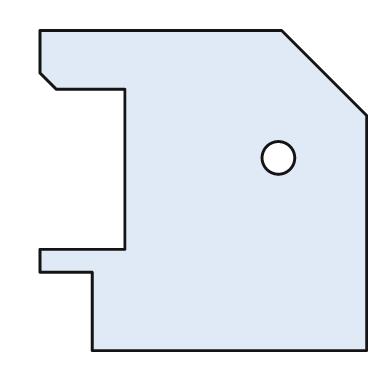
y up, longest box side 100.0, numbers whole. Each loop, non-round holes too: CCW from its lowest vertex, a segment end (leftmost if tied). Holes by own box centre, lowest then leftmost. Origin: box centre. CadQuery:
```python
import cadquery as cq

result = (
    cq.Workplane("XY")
    .moveTo(-34.0, -49.0)
    .lineTo(50.0, -49.0)
    .lineTo(50.0, 23.0)
    .lineTo(24.0, 49.0)
    .lineTo(-50.0, 49.0)
    .lineTo(-50.0, 36.0)
    .lineTo(-45.0, 31.0)
    .lineTo(-24.0, 31.0)
    .lineTo(-24.0, -18.0)
    .lineTo(-50.0, -18.0)
    .lineTo(-50.0, -25.0)
    .lineTo(-34.0, -25.0)
    .close()
    .moveTo(23.0, 10.0)
    .circle(5.0)
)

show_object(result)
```